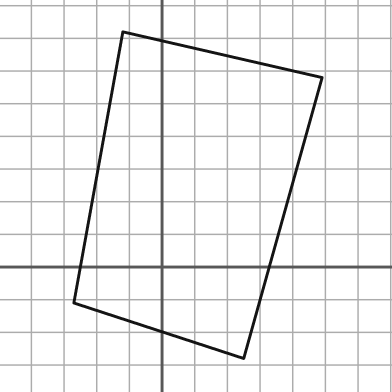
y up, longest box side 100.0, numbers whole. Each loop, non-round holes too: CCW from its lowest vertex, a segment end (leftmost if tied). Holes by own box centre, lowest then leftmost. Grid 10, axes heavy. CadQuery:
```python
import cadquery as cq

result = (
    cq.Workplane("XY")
    .moveTo(25.0, -28.0)
    .lineTo(49.0, 58.0)
    .lineTo(-12.0, 72.0)
    .lineTo(-27.0, -11.0)
    .close()
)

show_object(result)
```